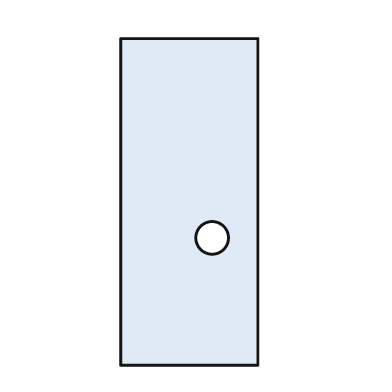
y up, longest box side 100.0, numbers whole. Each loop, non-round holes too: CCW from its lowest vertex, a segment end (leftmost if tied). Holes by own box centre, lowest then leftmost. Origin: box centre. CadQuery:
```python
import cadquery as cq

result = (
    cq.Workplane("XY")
    .moveTo(-21.0, -50.0)
    .lineTo(21.0, -50.0)
    .lineTo(21.0, 50.0)
    .lineTo(-21.0, 50.0)
    .close()
    .moveTo(7.0, -11.0)
    .circle(5.0)
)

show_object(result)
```